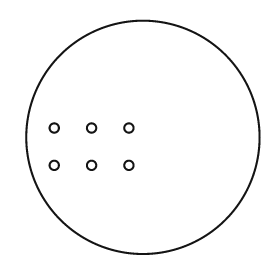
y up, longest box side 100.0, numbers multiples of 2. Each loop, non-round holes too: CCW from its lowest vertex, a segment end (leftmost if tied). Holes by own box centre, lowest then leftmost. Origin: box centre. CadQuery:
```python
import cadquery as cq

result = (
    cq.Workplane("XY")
    .moveTo(0.0, 0.0)
    .circle(50.0)
    .moveTo(-38.0, -12.0)
    .circle(2.0)
    .moveTo(-22.0, -12.0)
    .circle(2.0)
    .moveTo(-6.0, -12.0)
    .circle(2.0)
    .moveTo(-38.0, 4.0)
    .circle(2.0)
    .moveTo(-22.0, 4.0)
    .circle(2.0)
    .moveTo(-6.0, 4.0)
    .circle(2.0)
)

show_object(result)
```